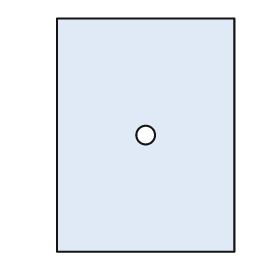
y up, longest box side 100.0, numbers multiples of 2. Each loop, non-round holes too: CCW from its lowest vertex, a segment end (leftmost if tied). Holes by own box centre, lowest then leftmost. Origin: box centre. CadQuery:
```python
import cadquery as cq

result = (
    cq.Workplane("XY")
    .moveTo(-38.0, -50.0)
    .lineTo(38.0, -50.0)
    .lineTo(38.0, 50.0)
    .lineTo(-38.0, 50.0)
    .close()
    .moveTo(0.0, 0.0)
    .circle(4.0)
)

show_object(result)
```